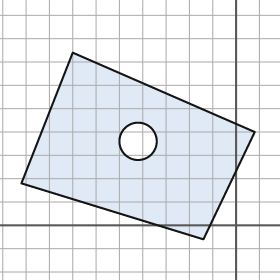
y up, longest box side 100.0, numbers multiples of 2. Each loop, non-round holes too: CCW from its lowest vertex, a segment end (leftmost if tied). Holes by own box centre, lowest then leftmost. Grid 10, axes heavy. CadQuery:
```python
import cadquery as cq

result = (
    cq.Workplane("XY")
    .moveTo(-14.0, -6.0)
    .lineTo(8.0, 40.0)
    .lineTo(-70.0, 74.0)
    .lineTo(-92.0, 18.0)
    .close()
    .moveTo(-42.0, 36.0)
    .circle(8.0)
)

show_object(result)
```